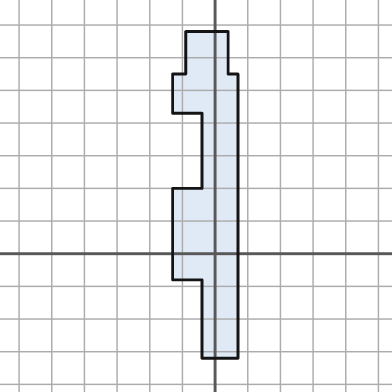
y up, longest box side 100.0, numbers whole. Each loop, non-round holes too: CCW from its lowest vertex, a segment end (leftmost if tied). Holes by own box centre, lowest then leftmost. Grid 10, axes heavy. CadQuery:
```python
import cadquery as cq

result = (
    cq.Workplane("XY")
    .moveTo(-4.0, -32.0)
    .lineTo(7.0, -32.0)
    .lineTo(7.0, 55.0)
    .lineTo(4.0, 55.0)
    .lineTo(4.0, 68.0)
    .lineTo(-9.0, 68.0)
    .lineTo(-9.0, 55.0)
    .lineTo(-13.0, 55.0)
    .lineTo(-13.0, 43.0)
    .lineTo(-4.0, 43.0)
    .lineTo(-4.0, 20.0)
    .lineTo(-13.0, 20.0)
    .lineTo(-13.0, -8.0)
    .lineTo(-4.0, -8.0)
    .close()
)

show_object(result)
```